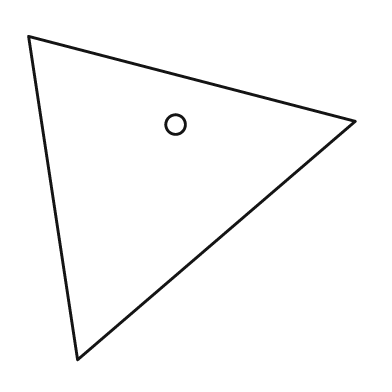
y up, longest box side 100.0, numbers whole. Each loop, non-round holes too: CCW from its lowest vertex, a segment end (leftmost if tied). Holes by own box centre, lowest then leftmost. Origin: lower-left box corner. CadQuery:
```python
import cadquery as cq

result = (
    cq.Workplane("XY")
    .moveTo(15.0, 0.0)
    .lineTo(100.0, 73.0)
    .lineTo(0.0, 99.0)
    .close()
    .moveTo(45.0, 72.0)
    .circle(3.0)
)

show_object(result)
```